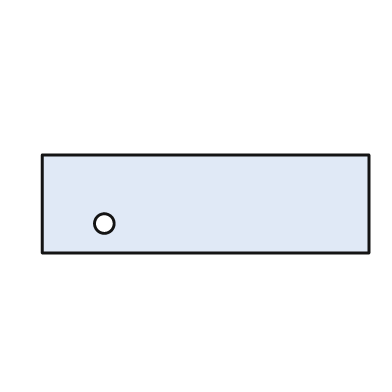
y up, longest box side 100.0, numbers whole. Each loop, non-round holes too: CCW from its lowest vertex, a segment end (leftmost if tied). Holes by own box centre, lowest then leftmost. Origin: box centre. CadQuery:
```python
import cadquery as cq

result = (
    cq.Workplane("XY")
    .moveTo(-50.0, -15.0)
    .lineTo(50.0, -15.0)
    .lineTo(50.0, 15.0)
    .lineTo(-50.0, 15.0)
    .close()
    .moveTo(-31.0, -6.0)
    .circle(3.0)
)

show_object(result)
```